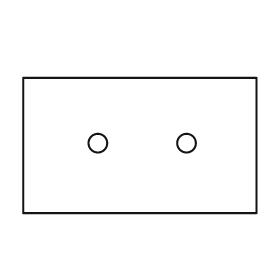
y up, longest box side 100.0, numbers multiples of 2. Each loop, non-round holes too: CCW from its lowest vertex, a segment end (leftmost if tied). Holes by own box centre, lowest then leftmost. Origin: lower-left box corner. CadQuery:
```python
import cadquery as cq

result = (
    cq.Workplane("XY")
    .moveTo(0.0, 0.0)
    .lineTo(100.0, 0.0)
    .lineTo(100.0, 58.0)
    .lineTo(0.0, 58.0)
    .close()
    .moveTo(32.0, 30.0)
    .circle(4.0)
    .moveTo(70.0, 30.0)
    .circle(4.0)
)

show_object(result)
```